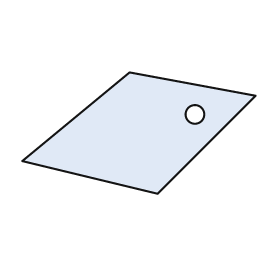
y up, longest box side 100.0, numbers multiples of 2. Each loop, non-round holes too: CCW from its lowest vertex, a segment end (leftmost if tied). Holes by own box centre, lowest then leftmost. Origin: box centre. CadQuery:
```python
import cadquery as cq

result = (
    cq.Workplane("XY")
    .moveTo(8.0, -26.0)
    .lineTo(50.0, 16.0)
    .lineTo(-4.0, 26.0)
    .lineTo(-50.0, -12.0)
    .close()
    .moveTo(24.0, 8.0)
    .circle(4.0)
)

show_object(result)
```